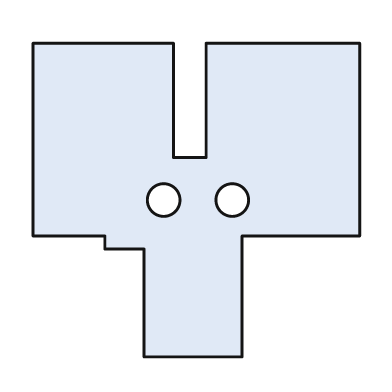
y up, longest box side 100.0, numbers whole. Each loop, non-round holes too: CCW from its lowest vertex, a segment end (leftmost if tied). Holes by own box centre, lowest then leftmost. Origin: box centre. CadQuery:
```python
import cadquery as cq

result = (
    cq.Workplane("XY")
    .moveTo(-16.0, -48.0)
    .lineTo(14.0, -48.0)
    .lineTo(14.0, -11.0)
    .lineTo(50.0, -11.0)
    .lineTo(50.0, 48.0)
    .lineTo(3.0, 48.0)
    .lineTo(3.0, 13.0)
    .lineTo(-7.0, 13.0)
    .lineTo(-7.0, 48.0)
    .lineTo(-50.0, 48.0)
    .lineTo(-50.0, -11.0)
    .lineTo(-28.0, -11.0)
    .lineTo(-28.0, -15.0)
    .lineTo(-16.0, -15.0)
    .close()
    .moveTo(-10.0, 0.0)
    .circle(5.0)
    .moveTo(11.0, 0.0)
    .circle(5.0)
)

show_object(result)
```